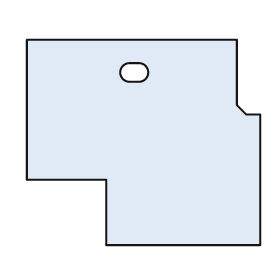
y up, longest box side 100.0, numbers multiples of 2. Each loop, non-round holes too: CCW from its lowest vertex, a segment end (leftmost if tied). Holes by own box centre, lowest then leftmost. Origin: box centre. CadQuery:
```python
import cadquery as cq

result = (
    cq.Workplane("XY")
    .moveTo(-16.0, -44.0)
    .lineTo(50.0, -44.0)
    .lineTo(50.0, 12.0)
    .lineTo(44.0, 12.0)
    .lineTo(40.0, 16.0)
    .lineTo(40.0, 44.0)
    .lineTo(-50.0, 44.0)
    .lineTo(-50.0, -16.0)
    .lineTo(-16.0, -16.0)
    .close()
    .moveTo(-6.0, 26.0)
    .lineTo(-2.0, 26.0)
    .threePointArc((2.0, 30.0), (-2.0, 34.0))
    .lineTo(-6.0, 34.0)
    .threePointArc((-10.0, 30.0), (-6.0, 26.0))
    .close()
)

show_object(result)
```